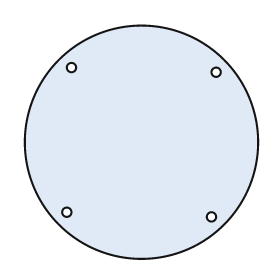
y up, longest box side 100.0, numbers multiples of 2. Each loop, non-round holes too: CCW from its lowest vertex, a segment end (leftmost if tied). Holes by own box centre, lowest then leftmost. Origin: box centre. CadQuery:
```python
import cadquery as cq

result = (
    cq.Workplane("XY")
    .moveTo(0.0, 0.0)
    .circle(50.0)
    .moveTo(30.0, -32.0)
    .circle(2.0)
    .moveTo(-32.0, -30.0)
    .circle(2.0)
    .moveTo(32.0, 30.0)
    .circle(2.0)
    .moveTo(-30.0, 32.0)
    .circle(2.0)
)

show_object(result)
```